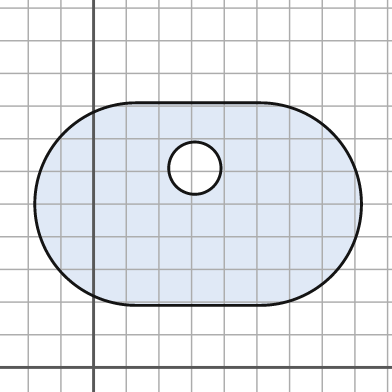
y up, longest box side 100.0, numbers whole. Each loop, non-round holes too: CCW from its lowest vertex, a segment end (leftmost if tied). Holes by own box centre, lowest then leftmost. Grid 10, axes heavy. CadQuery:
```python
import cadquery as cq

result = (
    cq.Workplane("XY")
    .moveTo(13.0, 19.0)
    .lineTo(51.0, 19.0)
    .threePointArc((82.0, 50.0), (51.0, 81.0))
    .lineTo(13.0, 81.0)
    .threePointArc((-18.0, 50.0), (13.0, 19.0))
    .close()
    .moveTo(31.0, 61.0)
    .circle(8.0)
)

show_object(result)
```